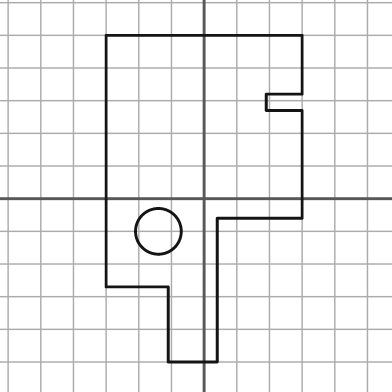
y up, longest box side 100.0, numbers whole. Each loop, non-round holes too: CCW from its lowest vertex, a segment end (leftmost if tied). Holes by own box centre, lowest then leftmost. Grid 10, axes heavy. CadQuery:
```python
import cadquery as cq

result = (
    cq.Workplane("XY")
    .moveTo(-11.0, -50.0)
    .lineTo(4.0, -50.0)
    .lineTo(4.0, -6.0)
    .lineTo(30.0, -6.0)
    .lineTo(30.0, 27.0)
    .lineTo(19.0, 27.0)
    .lineTo(19.0, 32.0)
    .lineTo(30.0, 32.0)
    .lineTo(30.0, 50.0)
    .lineTo(-30.0, 50.0)
    .lineTo(-30.0, -27.0)
    .lineTo(-11.0, -27.0)
    .close()
    .moveTo(-14.0, -10.0)
    .circle(7.0)
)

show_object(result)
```